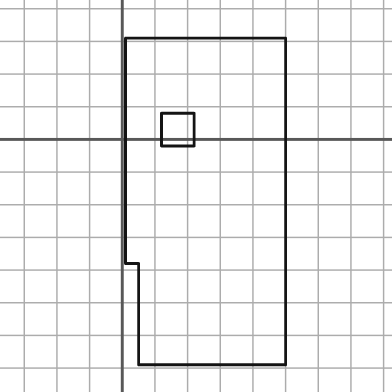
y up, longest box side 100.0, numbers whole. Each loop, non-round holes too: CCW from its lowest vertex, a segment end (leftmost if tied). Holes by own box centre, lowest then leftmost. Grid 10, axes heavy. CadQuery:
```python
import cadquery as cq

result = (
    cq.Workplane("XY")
    .moveTo(5.0, -69.0)
    .lineTo(50.0, -69.0)
    .lineTo(50.0, 31.0)
    .lineTo(1.0, 31.0)
    .lineTo(1.0, -38.0)
    .lineTo(5.0, -38.0)
    .close()
    .moveTo(12.0, -2.0)
    .lineTo(22.0, -2.0)
    .lineTo(22.0, 8.0)
    .lineTo(12.0, 8.0)
    .close()
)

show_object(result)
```